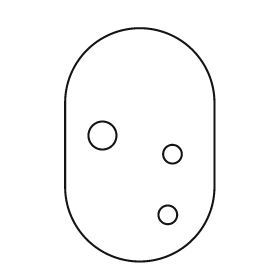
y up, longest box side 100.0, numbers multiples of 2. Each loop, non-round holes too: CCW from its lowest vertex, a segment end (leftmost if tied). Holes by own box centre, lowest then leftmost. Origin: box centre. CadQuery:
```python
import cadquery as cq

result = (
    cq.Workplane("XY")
    .moveTo(-32.0, -18.0)
    .threePointArc((0.0, -50.0), (32.0, -18.0))
    .lineTo(32.0, 18.0)
    .threePointArc((0.0, 50.0), (-32.0, 18.0))
    .close()
    .moveTo(12.0, -30.0)
    .circle(4.0)
    .moveTo(14.0, -4.0)
    .circle(4.0)
    .moveTo(-16.0, 4.0)
    .circle(6.0)
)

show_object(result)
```